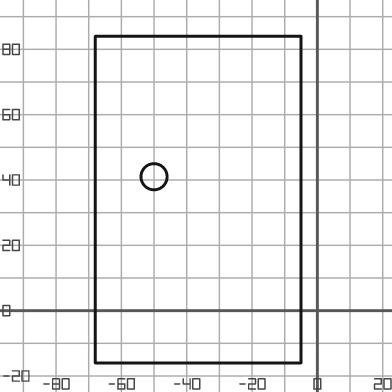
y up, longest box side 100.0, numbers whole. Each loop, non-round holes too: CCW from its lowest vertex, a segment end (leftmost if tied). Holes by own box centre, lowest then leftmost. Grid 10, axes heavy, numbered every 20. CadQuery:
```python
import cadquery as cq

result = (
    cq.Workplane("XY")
    .moveTo(-68.0, -16.0)
    .lineTo(-5.0, -16.0)
    .lineTo(-5.0, 84.0)
    .lineTo(-68.0, 84.0)
    .close()
    .moveTo(-50.0, 41.0)
    .circle(4.0)
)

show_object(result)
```